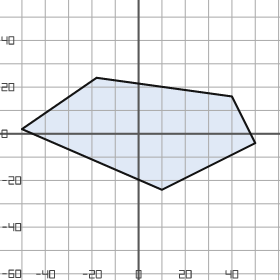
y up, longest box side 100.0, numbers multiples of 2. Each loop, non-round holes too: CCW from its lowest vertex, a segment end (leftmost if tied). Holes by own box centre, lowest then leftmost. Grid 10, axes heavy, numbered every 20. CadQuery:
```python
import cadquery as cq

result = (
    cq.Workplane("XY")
    .moveTo(10.0, -24.0)
    .lineTo(50.0, -4.0)
    .lineTo(40.0, 16.0)
    .lineTo(-18.0, 24.0)
    .lineTo(-50.0, 2.0)
    .close()
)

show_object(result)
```